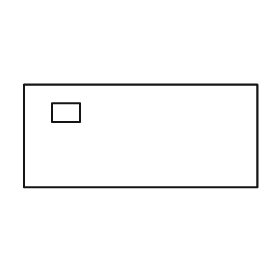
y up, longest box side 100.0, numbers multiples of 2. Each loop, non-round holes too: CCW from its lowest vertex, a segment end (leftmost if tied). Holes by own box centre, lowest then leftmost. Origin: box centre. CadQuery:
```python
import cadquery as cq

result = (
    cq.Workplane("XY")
    .moveTo(-50.0, -22.0)
    .lineTo(50.0, -22.0)
    .lineTo(50.0, 22.0)
    .lineTo(-50.0, 22.0)
    .close()
    .moveTo(-38.0, 6.0)
    .lineTo(-26.0, 6.0)
    .lineTo(-26.0, 14.0)
    .lineTo(-38.0, 14.0)
    .close()
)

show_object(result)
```